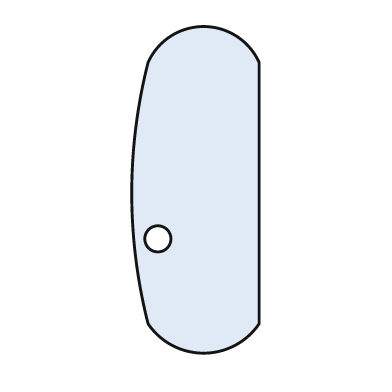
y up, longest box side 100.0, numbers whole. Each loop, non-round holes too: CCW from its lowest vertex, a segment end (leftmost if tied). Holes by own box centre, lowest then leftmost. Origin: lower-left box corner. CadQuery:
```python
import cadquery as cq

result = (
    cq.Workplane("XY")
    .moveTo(5.0, 9.0)
    .threePointArc((22.0, 0.0), (39.0, 9.0))
    .lineTo(39.0, 89.0)
    .threePointArc((22.0, 100.0), (5.0, 89.0))
    .threePointArc((0.0, 49.0), (5.0, 9.0))
    .close()
    .moveTo(8.0, 35.0)
    .circle(4.0)
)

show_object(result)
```